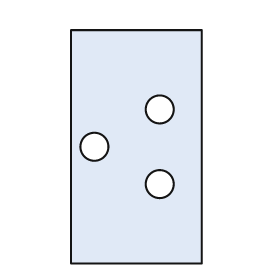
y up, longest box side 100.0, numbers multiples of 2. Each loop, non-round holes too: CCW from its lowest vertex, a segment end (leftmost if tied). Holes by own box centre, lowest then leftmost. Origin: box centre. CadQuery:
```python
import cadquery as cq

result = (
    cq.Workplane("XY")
    .moveTo(-28.0, -50.0)
    .lineTo(28.0, -50.0)
    .lineTo(28.0, 50.0)
    .lineTo(-28.0, 50.0)
    .close()
    .moveTo(10.0, -16.0)
    .circle(6.0)
    .moveTo(-18.0, 0.0)
    .circle(6.0)
    .moveTo(10.0, 16.0)
    .circle(6.0)
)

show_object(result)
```